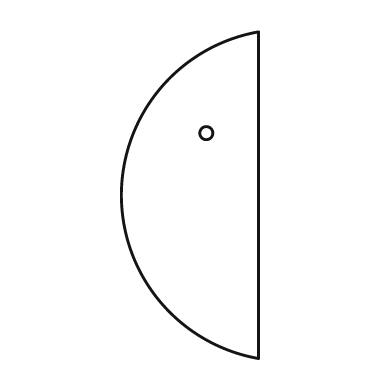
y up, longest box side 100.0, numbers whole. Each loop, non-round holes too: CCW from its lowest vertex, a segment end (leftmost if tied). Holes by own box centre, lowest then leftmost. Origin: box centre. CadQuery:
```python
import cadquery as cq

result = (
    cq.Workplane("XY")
    .moveTo(21.0, -50.0)
    .lineTo(21.0, 50.0)
    .threePointArc((-21.0, 0.0), (21.0, -50.0))
    .close()
    .moveTo(5.0, 19.0)
    .circle(2.0)
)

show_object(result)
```